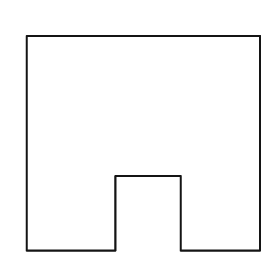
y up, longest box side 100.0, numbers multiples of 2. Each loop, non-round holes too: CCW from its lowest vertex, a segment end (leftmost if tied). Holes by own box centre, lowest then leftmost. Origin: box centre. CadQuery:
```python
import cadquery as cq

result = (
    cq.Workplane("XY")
    .moveTo(-50.0, -46.0)
    .lineTo(-12.0, -46.0)
    .lineTo(-12.0, -14.0)
    .lineTo(16.0, -14.0)
    .lineTo(16.0, -46.0)
    .lineTo(50.0, -46.0)
    .lineTo(50.0, 46.0)
    .lineTo(-50.0, 46.0)
    .close()
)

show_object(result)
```